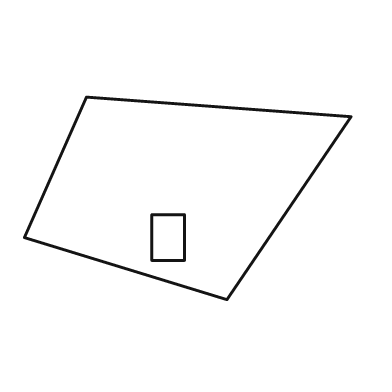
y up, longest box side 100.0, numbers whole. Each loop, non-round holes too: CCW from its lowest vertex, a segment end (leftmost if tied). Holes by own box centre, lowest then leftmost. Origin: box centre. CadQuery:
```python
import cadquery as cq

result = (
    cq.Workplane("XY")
    .moveTo(12.0, -31.0)
    .lineTo(50.0, 25.0)
    .lineTo(-31.0, 31.0)
    .lineTo(-50.0, -12.0)
    .close()
    .moveTo(-11.0, -19.0)
    .lineTo(-1.0, -19.0)
    .lineTo(-1.0, -5.0)
    .lineTo(-11.0, -5.0)
    .close()
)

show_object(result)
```